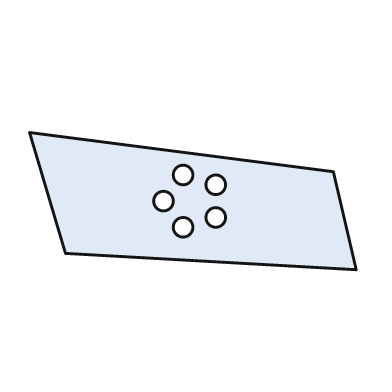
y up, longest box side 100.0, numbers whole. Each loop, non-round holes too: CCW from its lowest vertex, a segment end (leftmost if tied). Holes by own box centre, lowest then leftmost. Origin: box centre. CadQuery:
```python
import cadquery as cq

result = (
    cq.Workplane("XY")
    .moveTo(50.0, -21.0)
    .lineTo(43.0, 9.0)
    .lineTo(-50.0, 21.0)
    .lineTo(-39.0, -16.0)
    .close()
    .moveTo(-3.0, -8.0)
    .circle(3.0)
    .moveTo(7.0, -5.0)
    .circle(3.0)
    .moveTo(-9.0, 0.0)
    .circle(3.0)
    .moveTo(7.0, 5.0)
    .circle(3.0)
    .moveTo(-3.0, 8.0)
    .circle(3.0)
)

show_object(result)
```